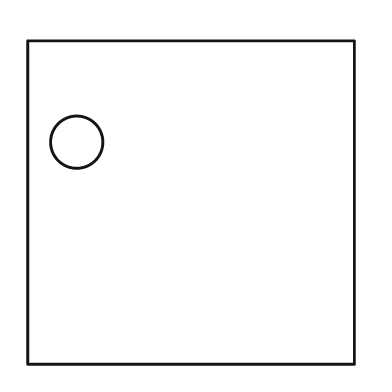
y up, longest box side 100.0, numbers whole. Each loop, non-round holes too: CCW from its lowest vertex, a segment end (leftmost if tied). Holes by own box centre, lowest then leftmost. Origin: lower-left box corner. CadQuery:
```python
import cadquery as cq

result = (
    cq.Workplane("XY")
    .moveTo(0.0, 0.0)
    .lineTo(100.0, 0.0)
    .lineTo(100.0, 99.0)
    .lineTo(0.0, 99.0)
    .close()
    .moveTo(15.0, 68.0)
    .circle(8.0)
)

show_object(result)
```